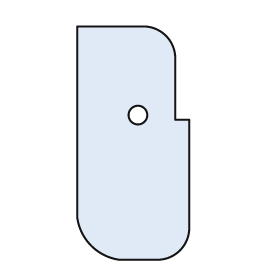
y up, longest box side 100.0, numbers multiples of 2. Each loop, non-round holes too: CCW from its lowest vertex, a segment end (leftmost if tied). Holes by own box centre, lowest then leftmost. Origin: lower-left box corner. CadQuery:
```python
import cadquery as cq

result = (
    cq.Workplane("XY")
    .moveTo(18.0, 0.0)
    .lineTo(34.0, 0.0)
    .threePointArc((44.0, 4.0), (48.0, 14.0))
    .lineTo(48.0, 60.0)
    .lineTo(42.0, 60.0)
    .lineTo(42.0, 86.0)
    .threePointArc((38.0, 96.0), (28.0, 100.0))
    .lineTo(0.0, 100.0)
    .lineTo(0.0, 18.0)
    .threePointArc((6.0, 6.0), (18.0, 0.0))
    .close()
    .moveTo(26.0, 62.0)
    .circle(4.0)
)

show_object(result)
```